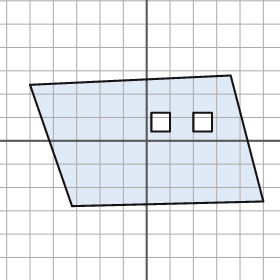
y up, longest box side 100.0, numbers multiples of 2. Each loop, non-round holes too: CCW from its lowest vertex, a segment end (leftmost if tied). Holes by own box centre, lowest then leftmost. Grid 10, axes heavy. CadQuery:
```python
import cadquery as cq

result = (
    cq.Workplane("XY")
    .moveTo(-32.0, -28.0)
    .lineTo(50.0, -26.0)
    .lineTo(36.0, 28.0)
    .lineTo(-50.0, 24.0)
    .close()
    .moveTo(2.0, 4.0)
    .lineTo(10.0, 4.0)
    .lineTo(10.0, 12.0)
    .lineTo(2.0, 12.0)
    .close()
    .moveTo(20.0, 4.0)
    .lineTo(28.0, 4.0)
    .lineTo(28.0, 12.0)
    .lineTo(20.0, 12.0)
    .close()
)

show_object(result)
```